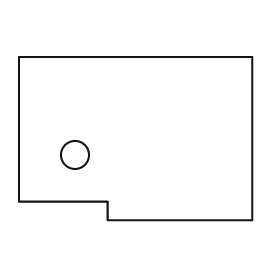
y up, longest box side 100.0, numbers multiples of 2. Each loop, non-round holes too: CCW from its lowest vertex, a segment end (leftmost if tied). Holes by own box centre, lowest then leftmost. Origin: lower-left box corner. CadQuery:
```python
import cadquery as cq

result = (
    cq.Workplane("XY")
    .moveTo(38.0, 0.0)
    .lineTo(100.0, 0.0)
    .lineTo(100.0, 70.0)
    .lineTo(0.0, 70.0)
    .lineTo(0.0, 8.0)
    .lineTo(38.0, 8.0)
    .close()
    .moveTo(24.0, 28.0)
    .circle(6.0)
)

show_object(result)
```